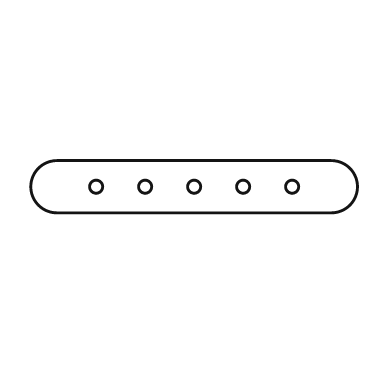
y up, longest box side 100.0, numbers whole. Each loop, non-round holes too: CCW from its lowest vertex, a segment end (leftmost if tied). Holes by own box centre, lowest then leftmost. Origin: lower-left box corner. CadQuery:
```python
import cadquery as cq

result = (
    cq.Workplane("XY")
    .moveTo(8.0, 0.0)
    .lineTo(92.0, 0.0)
    .threePointArc((100.0, 8.0), (92.0, 16.0))
    .lineTo(8.0, 16.0)
    .threePointArc((0.0, 8.0), (8.0, 0.0))
    .close()
    .moveTo(20.0, 8.0)
    .circle(2.0)
    .moveTo(35.0, 8.0)
    .circle(2.0)
    .moveTo(50.0, 8.0)
    .circle(2.0)
    .moveTo(65.0, 8.0)
    .circle(2.0)
    .moveTo(80.0, 8.0)
    .circle(2.0)
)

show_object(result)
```